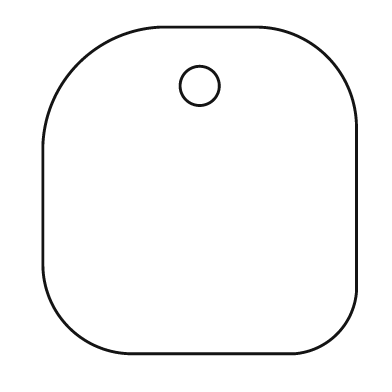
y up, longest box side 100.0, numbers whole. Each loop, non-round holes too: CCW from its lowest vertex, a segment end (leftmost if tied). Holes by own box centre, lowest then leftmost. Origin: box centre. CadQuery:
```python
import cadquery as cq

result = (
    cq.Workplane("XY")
    .moveTo(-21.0, -50.0)
    .lineTo(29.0, -50.0)
    .threePointArc((42.0, -44.0), (48.0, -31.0))
    .lineTo(48.0, 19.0)
    .threePointArc((39.0, 41.0), (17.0, 50.0))
    .lineTo(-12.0, 50.0)
    .threePointArc((-37.0, 39.0), (-48.0, 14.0))
    .lineTo(-48.0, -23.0)
    .threePointArc((-40.0, -42.0), (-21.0, -50.0))
    .close()
    .moveTo(0.0, 32.0)
    .circle(6.0)
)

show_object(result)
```